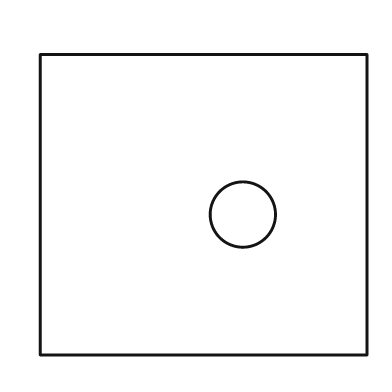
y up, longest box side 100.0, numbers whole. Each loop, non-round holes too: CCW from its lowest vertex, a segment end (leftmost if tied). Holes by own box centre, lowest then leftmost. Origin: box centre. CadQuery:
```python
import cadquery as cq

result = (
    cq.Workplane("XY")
    .moveTo(-50.0, -46.0)
    .lineTo(50.0, -46.0)
    .lineTo(50.0, 46.0)
    .lineTo(-50.0, 46.0)
    .close()
    .moveTo(12.0, -3.0)
    .circle(10.0)
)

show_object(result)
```